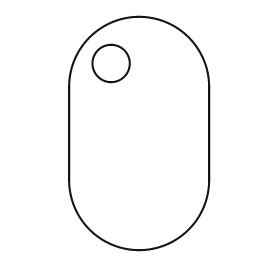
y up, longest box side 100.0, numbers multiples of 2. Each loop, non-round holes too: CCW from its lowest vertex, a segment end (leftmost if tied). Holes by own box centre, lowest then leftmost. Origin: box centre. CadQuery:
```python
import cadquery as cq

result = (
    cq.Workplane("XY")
    .moveTo(-30.0, -20.0)
    .threePointArc((0.0, -50.0), (30.0, -20.0))
    .lineTo(30.0, 20.0)
    .threePointArc((0.0, 50.0), (-30.0, 20.0))
    .close()
    .moveTo(-12.0, 30.0)
    .circle(8.0)
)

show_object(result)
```